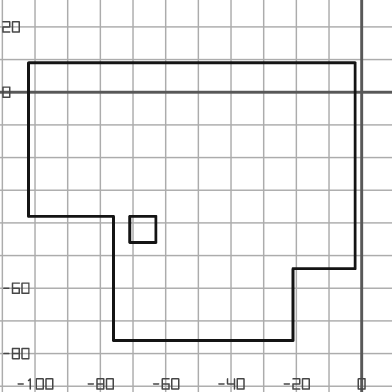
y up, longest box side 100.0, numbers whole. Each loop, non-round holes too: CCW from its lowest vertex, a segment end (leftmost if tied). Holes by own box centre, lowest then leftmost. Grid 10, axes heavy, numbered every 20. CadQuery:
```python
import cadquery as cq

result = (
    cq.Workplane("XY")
    .moveTo(-76.0, -76.0)
    .lineTo(-21.0, -76.0)
    .lineTo(-21.0, -54.0)
    .lineTo(-2.0, -54.0)
    .lineTo(-2.0, 9.0)
    .lineTo(-102.0, 9.0)
    .lineTo(-102.0, -38.0)
    .lineTo(-76.0, -38.0)
    .close()
    .moveTo(-71.0, -46.0)
    .lineTo(-63.0, -46.0)
    .lineTo(-63.0, -38.0)
    .lineTo(-71.0, -38.0)
    .close()
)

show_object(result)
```